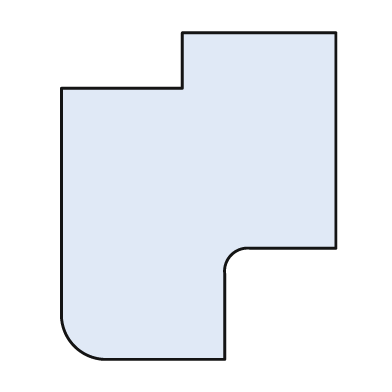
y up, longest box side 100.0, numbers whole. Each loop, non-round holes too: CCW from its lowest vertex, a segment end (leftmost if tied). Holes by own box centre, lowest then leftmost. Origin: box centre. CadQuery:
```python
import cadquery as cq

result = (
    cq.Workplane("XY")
    .moveTo(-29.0, -50.0)
    .lineTo(8.0, -50.0)
    .lineTo(8.0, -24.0)
    .threePointArc((10.0, -18.0), (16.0, -16.0))
    .lineTo(42.0, -16.0)
    .lineTo(42.0, 50.0)
    .lineTo(-5.0, 50.0)
    .lineTo(-5.0, 33.0)
    .lineTo(-42.0, 33.0)
    .lineTo(-42.0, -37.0)
    .threePointArc((-38.0, -46.0), (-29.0, -50.0))
    .close()
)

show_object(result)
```